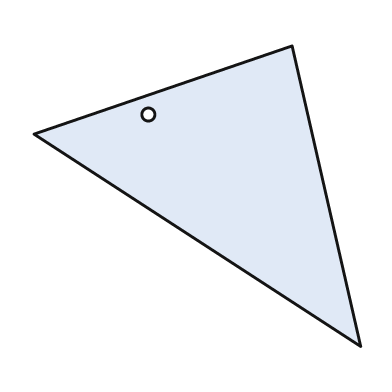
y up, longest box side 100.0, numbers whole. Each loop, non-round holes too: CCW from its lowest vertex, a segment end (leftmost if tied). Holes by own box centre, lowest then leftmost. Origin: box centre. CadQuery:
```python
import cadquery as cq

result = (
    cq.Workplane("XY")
    .moveTo(50.0, -46.0)
    .lineTo(29.0, 46.0)
    .lineTo(-50.0, 19.0)
    .close()
    .moveTo(-15.0, 25.0)
    .circle(2.0)
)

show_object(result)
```